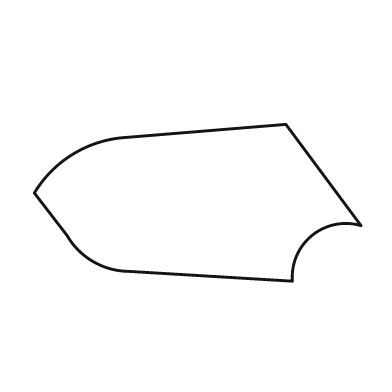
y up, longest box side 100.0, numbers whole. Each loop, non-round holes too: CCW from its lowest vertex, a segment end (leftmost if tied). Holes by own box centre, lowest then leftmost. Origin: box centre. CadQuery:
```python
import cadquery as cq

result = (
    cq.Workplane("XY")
    .moveTo(29.0, -24.0)
    .threePointArc((35.0, -10.0), (50.0, -7.0))
    .lineTo(27.0, 24.0)
    .lineTo(-22.0, 20.0)
    .threePointArc((-38.0, 15.0), (-50.0, 3.0))
    .lineTo(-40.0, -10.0)
    .threePointArc((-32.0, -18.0), (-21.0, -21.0))
    .close()
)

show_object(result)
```